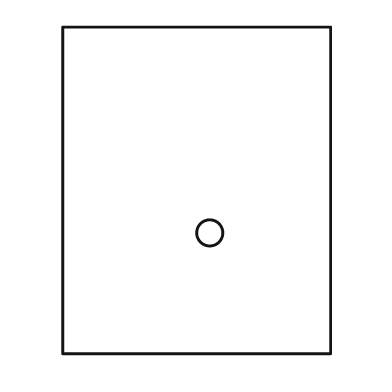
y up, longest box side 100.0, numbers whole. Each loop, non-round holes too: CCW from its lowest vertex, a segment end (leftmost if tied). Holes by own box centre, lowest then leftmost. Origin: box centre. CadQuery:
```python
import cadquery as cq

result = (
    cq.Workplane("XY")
    .moveTo(-41.0, -50.0)
    .lineTo(41.0, -50.0)
    .lineTo(41.0, 50.0)
    .lineTo(-41.0, 50.0)
    .close()
    .moveTo(4.0, -13.0)
    .circle(4.0)
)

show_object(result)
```